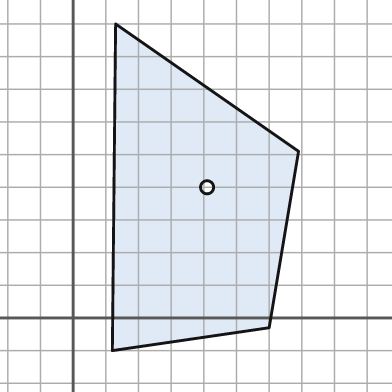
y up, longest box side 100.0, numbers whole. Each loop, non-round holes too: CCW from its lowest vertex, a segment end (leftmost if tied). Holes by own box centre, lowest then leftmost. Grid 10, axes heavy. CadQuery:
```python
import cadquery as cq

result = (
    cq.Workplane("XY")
    .moveTo(12.0, -10.0)
    .lineTo(60.0, -3.0)
    .lineTo(69.0, 51.0)
    .lineTo(13.0, 90.0)
    .close()
    .moveTo(41.0, 40.0)
    .circle(2.0)
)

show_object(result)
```